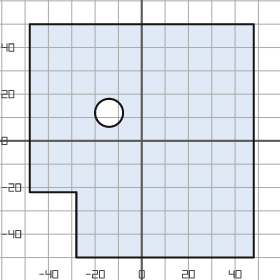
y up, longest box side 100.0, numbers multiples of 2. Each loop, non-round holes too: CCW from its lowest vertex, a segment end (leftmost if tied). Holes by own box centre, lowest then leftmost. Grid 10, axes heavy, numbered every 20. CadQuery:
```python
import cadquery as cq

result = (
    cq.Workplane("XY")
    .moveTo(-28.0, -50.0)
    .lineTo(48.0, -50.0)
    .lineTo(48.0, 50.0)
    .lineTo(-48.0, 50.0)
    .lineTo(-48.0, -22.0)
    .lineTo(-28.0, -22.0)
    .close()
    .moveTo(-14.0, 12.0)
    .circle(6.0)
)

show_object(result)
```